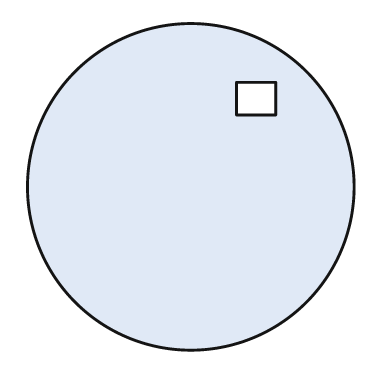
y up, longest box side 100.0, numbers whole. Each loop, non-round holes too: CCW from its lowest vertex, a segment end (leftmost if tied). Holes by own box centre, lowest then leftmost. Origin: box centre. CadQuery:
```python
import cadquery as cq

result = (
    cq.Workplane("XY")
    .moveTo(0.0, 0.0)
    .circle(50.0)
    .moveTo(14.0, 22.0)
    .lineTo(26.0, 22.0)
    .lineTo(26.0, 32.0)
    .lineTo(14.0, 32.0)
    .close()
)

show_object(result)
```